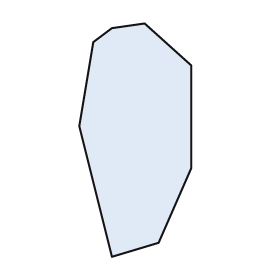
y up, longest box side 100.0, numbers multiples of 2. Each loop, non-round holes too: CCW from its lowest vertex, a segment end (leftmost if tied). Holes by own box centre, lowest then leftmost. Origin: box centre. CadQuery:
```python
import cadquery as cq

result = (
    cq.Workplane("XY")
    .moveTo(-10.0, -50.0)
    .lineTo(10.0, -44.0)
    .lineTo(24.0, -12.0)
    .lineTo(24.0, 32.0)
    .lineTo(4.0, 50.0)
    .lineTo(-10.0, 48.0)
    .lineTo(-18.0, 42.0)
    .lineTo(-24.0, 6.0)
    .close()
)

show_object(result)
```